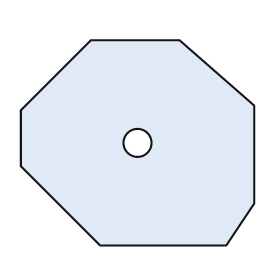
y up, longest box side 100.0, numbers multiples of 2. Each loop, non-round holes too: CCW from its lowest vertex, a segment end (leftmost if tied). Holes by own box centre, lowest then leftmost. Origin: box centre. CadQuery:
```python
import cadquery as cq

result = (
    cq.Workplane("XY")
    .moveTo(-16.0, -44.0)
    .lineTo(38.0, -44.0)
    .lineTo(50.0, -26.0)
    .lineTo(50.0, 16.0)
    .lineTo(18.0, 44.0)
    .lineTo(-20.0, 44.0)
    .lineTo(-50.0, 14.0)
    .lineTo(-50.0, -10.0)
    .close()
    .moveTo(0.0, 0.0)
    .circle(6.0)
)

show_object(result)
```